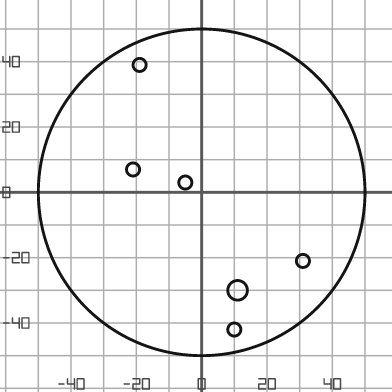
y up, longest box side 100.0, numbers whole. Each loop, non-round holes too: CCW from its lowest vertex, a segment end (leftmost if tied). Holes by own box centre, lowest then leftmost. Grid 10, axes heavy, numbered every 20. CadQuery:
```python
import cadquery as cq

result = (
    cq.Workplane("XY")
    .moveTo(0.0, 0.0)
    .circle(50.0)
    .moveTo(10.0, -42.0)
    .circle(2.0)
    .moveTo(11.0, -30.0)
    .circle(3.0)
    .moveTo(31.0, -21.0)
    .circle(2.0)
    .moveTo(-5.0, 3.0)
    .circle(2.0)
    .moveTo(-21.0, 7.0)
    .circle(2.0)
    .moveTo(-19.0, 39.0)
    .circle(2.0)
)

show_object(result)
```